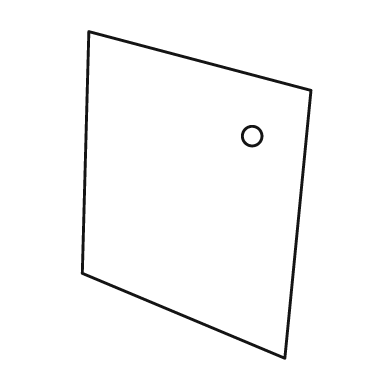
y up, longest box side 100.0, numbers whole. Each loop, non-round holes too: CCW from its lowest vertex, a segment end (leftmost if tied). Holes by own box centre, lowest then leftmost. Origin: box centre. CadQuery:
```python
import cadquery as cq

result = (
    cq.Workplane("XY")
    .moveTo(27.0, -50.0)
    .lineTo(35.0, 32.0)
    .lineTo(-33.0, 50.0)
    .lineTo(-35.0, -24.0)
    .close()
    .moveTo(17.0, 18.0)
    .circle(3.0)
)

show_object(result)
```